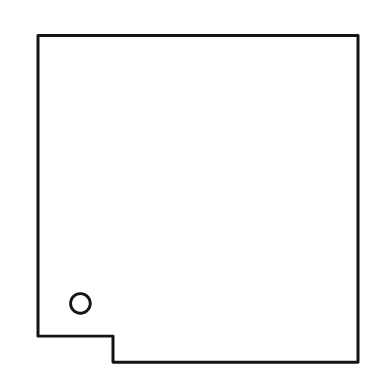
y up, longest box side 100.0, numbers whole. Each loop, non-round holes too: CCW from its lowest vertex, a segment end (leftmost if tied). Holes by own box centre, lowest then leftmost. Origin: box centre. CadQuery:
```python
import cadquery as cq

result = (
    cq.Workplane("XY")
    .moveTo(-26.0, -50.0)
    .lineTo(49.0, -50.0)
    .lineTo(49.0, 50.0)
    .lineTo(-49.0, 50.0)
    .lineTo(-49.0, -42.0)
    .lineTo(-26.0, -42.0)
    .close()
    .moveTo(-36.0, -32.0)
    .circle(3.0)
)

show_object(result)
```